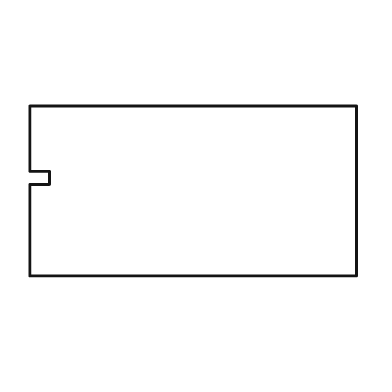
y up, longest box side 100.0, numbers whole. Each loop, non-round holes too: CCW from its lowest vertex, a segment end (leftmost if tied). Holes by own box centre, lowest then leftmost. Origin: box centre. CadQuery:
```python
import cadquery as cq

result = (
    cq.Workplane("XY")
    .moveTo(-50.0, -26.0)
    .lineTo(50.0, -26.0)
    .lineTo(50.0, 26.0)
    .lineTo(-50.0, 26.0)
    .lineTo(-50.0, 6.0)
    .lineTo(-44.0, 6.0)
    .lineTo(-44.0, 2.0)
    .lineTo(-50.0, 2.0)
    .close()
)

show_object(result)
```